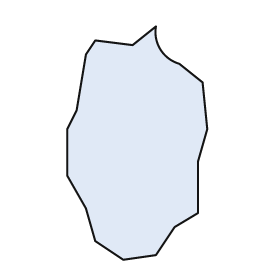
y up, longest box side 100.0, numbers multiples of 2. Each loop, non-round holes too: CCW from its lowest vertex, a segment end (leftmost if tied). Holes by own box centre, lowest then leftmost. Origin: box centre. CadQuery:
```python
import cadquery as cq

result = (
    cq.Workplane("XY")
    .moveTo(-6.0, -50.0)
    .lineTo(8.0, -48.0)
    .lineTo(16.0, -36.0)
    .lineTo(26.0, -30.0)
    .lineTo(26.0, -8.0)
    .lineTo(30.0, 6.0)
    .lineTo(28.0, 26.0)
    .lineTo(18.0, 34.0)
    .threePointArc((10.0, 40.0), (8.0, 50.0))
    .lineTo(-2.0, 42.0)
    .lineTo(-18.0, 44.0)
    .lineTo(-22.0, 38.0)
    .lineTo(-26.0, 14.0)
    .lineTo(-30.0, 6.0)
    .lineTo(-30.0, -14.0)
    .lineTo(-22.0, -28.0)
    .lineTo(-18.0, -42.0)
    .close()
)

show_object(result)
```